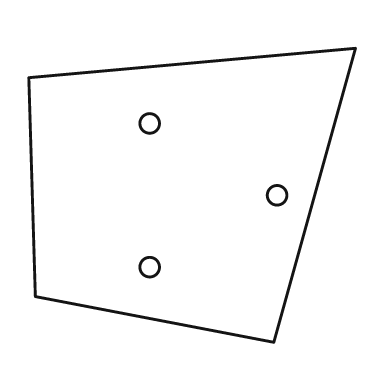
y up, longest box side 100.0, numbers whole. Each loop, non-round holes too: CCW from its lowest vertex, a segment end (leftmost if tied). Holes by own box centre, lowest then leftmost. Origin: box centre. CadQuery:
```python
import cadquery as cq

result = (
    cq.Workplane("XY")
    .moveTo(25.0, -45.0)
    .lineTo(50.0, 45.0)
    .lineTo(-50.0, 36.0)
    .lineTo(-48.0, -31.0)
    .close()
    .moveTo(-13.0, -22.0)
    .circle(3.0)
    .moveTo(26.0, 0.0)
    .circle(3.0)
    .moveTo(-13.0, 22.0)
    .circle(3.0)
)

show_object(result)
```